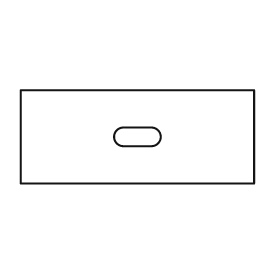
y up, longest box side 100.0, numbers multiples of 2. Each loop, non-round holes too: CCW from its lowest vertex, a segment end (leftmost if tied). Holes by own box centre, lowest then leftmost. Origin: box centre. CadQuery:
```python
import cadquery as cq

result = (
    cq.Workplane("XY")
    .moveTo(-50.0, -20.0)
    .lineTo(50.0, -20.0)
    .lineTo(50.0, 20.0)
    .lineTo(-50.0, 20.0)
    .close()
    .moveTo(-6.0, -4.0)
    .lineTo(6.0, -4.0)
    .threePointArc((10.0, 0.0), (6.0, 4.0))
    .lineTo(-6.0, 4.0)
    .threePointArc((-10.0, 0.0), (-6.0, -4.0))
    .close()
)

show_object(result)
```